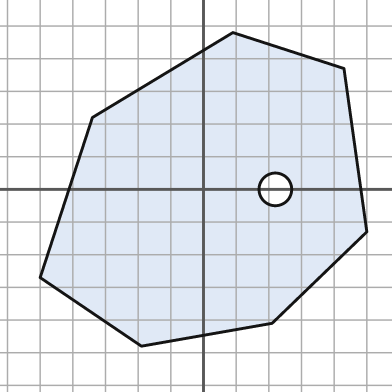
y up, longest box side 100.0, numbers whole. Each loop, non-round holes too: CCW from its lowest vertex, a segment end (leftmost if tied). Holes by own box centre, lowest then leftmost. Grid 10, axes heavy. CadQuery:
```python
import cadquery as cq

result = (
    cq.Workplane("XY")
    .moveTo(-19.0, -48.0)
    .lineTo(21.0, -41.0)
    .lineTo(50.0, -13.0)
    .lineTo(43.0, 37.0)
    .lineTo(9.0, 48.0)
    .lineTo(-34.0, 22.0)
    .lineTo(-50.0, -27.0)
    .close()
    .moveTo(22.0, 0.0)
    .circle(5.0)
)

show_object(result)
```